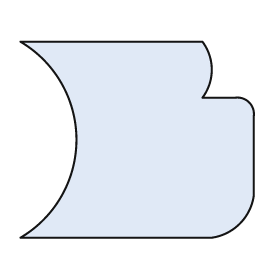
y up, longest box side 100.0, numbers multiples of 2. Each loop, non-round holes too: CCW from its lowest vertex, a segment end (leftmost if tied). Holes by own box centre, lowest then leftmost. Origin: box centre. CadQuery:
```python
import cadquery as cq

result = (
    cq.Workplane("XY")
    .moveTo(-50.0, -42.0)
    .lineTo(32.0, -42.0)
    .threePointArc((44.0, -36.0), (50.0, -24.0))
    .lineTo(50.0, 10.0)
    .threePointArc((48.0, 16.0), (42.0, 18.0))
    .lineTo(28.0, 18.0)
    .threePointArc((32.0, 30.0), (28.0, 42.0))
    .lineTo(-50.0, 42.0)
    .threePointArc((-26.0, 0.0), (-50.0, -42.0))
    .close()
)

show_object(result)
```